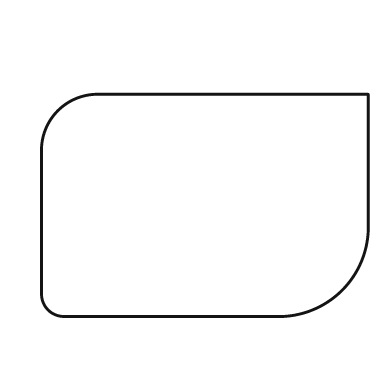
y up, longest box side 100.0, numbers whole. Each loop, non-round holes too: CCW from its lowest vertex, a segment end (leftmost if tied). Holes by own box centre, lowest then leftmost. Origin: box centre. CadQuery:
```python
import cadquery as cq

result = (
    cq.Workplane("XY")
    .moveTo(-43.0, -34.0)
    .lineTo(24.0, -34.0)
    .threePointArc((42.0, -26.0), (50.0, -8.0))
    .lineTo(50.0, 34.0)
    .lineTo(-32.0, 34.0)
    .threePointArc((-45.0, 29.0), (-50.0, 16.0))
    .lineTo(-50.0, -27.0)
    .threePointArc((-48.0, -32.0), (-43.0, -34.0))
    .close()
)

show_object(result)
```